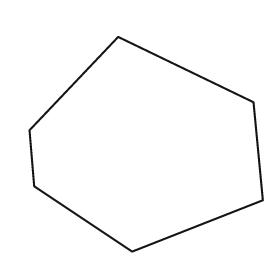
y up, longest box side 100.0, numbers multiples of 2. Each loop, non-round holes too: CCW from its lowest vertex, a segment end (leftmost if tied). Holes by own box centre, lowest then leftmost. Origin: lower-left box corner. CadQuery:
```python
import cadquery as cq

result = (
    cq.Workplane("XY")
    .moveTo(44.0, 0.0)
    .lineTo(100.0, 22.0)
    .lineTo(96.0, 64.0)
    .lineTo(38.0, 92.0)
    .lineTo(0.0, 52.0)
    .lineTo(2.0, 28.0)
    .close()
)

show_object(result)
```